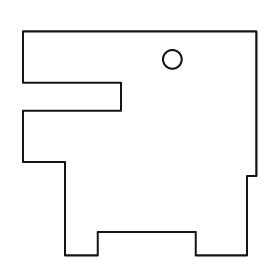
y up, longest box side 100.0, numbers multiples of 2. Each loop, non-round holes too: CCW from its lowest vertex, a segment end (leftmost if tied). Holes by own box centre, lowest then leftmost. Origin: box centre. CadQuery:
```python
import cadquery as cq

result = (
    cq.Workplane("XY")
    .moveTo(-32.0, -48.0)
    .lineTo(-18.0, -48.0)
    .lineTo(-18.0, -38.0)
    .lineTo(24.0, -38.0)
    .lineTo(24.0, -48.0)
    .lineTo(46.0, -48.0)
    .lineTo(46.0, -14.0)
    .lineTo(50.0, -14.0)
    .lineTo(50.0, 48.0)
    .lineTo(-50.0, 48.0)
    .lineTo(-50.0, 26.0)
    .lineTo(-8.0, 26.0)
    .lineTo(-8.0, 14.0)
    .lineTo(-50.0, 14.0)
    .lineTo(-50.0, -8.0)
    .lineTo(-32.0, -8.0)
    .close()
    .moveTo(14.0, 36.0)
    .circle(4.0)
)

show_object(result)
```